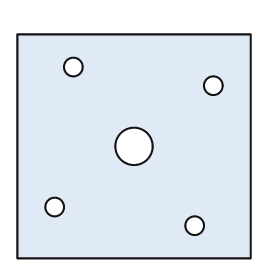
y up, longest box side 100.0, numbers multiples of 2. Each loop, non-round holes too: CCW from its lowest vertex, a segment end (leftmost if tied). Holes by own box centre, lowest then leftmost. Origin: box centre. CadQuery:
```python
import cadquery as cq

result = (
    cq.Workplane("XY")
    .moveTo(-50.0, -48.0)
    .lineTo(50.0, -48.0)
    .lineTo(50.0, 48.0)
    .lineTo(-50.0, 48.0)
    .close()
    .moveTo(26.0, -34.0)
    .circle(4.0)
    .moveTo(-34.0, -26.0)
    .circle(4.0)
    .moveTo(0.0, 0.0)
    .circle(8.0)
    .moveTo(34.0, 26.0)
    .circle(4.0)
    .moveTo(-26.0, 34.0)
    .circle(4.0)
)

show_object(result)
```